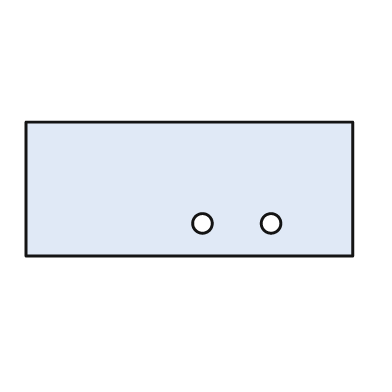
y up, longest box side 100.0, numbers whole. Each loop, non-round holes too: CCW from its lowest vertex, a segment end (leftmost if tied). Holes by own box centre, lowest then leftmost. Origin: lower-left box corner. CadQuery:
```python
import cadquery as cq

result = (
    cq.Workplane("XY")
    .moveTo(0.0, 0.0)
    .lineTo(100.0, 0.0)
    .lineTo(100.0, 41.0)
    .lineTo(0.0, 41.0)
    .close()
    .moveTo(54.0, 10.0)
    .circle(3.0)
    .moveTo(75.0, 10.0)
    .circle(3.0)
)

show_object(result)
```